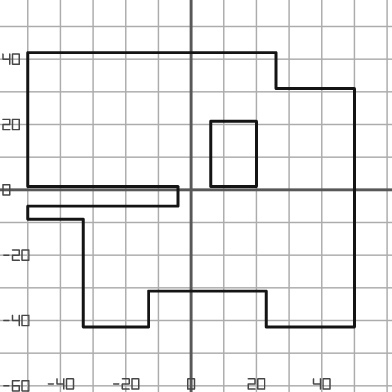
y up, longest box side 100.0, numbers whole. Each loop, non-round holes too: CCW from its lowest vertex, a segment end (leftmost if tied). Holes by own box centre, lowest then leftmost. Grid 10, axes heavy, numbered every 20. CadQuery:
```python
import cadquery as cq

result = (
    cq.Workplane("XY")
    .moveTo(-33.0, -42.0)
    .lineTo(-13.0, -42.0)
    .lineTo(-13.0, -31.0)
    .lineTo(23.0, -31.0)
    .lineTo(23.0, -42.0)
    .lineTo(50.0, -42.0)
    .lineTo(50.0, 31.0)
    .lineTo(26.0, 31.0)
    .lineTo(26.0, 42.0)
    .lineTo(-50.0, 42.0)
    .lineTo(-50.0, 1.0)
    .lineTo(-4.0, 1.0)
    .lineTo(-4.0, -5.0)
    .lineTo(-50.0, -5.0)
    .lineTo(-50.0, -9.0)
    .lineTo(-33.0, -9.0)
    .close()
    .moveTo(6.0, 1.0)
    .lineTo(20.0, 1.0)
    .lineTo(20.0, 21.0)
    .lineTo(6.0, 21.0)
    .close()
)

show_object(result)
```